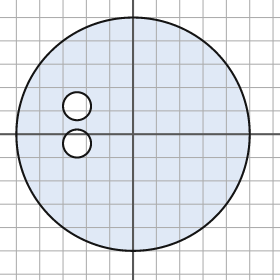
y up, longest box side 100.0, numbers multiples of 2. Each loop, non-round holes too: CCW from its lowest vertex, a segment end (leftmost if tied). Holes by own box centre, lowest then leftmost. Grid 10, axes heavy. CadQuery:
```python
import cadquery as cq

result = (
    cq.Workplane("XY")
    .moveTo(0.0, 0.0)
    .circle(50.0)
    .moveTo(-24.0, -4.0)
    .circle(6.0)
    .moveTo(-24.0, 12.0)
    .circle(6.0)
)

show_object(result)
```